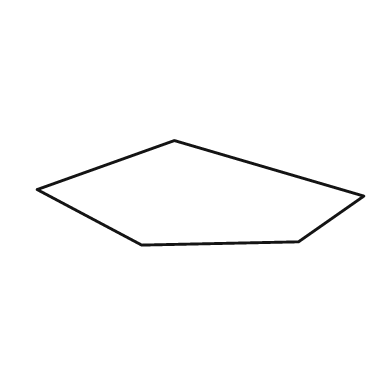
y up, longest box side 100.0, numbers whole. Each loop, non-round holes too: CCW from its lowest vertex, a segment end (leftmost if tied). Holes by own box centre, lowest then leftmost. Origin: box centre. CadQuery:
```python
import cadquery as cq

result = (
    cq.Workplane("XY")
    .moveTo(-18.0, -16.0)
    .lineTo(30.0, -15.0)
    .lineTo(50.0, -1.0)
    .lineTo(-8.0, 16.0)
    .lineTo(-50.0, 1.0)
    .close()
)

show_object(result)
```